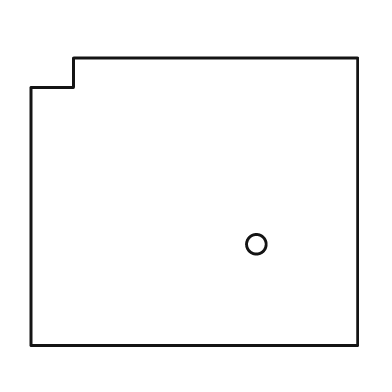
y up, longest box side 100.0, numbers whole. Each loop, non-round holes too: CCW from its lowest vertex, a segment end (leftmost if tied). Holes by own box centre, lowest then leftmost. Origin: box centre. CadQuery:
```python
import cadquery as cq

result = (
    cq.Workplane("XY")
    .moveTo(-50.0, -44.0)
    .lineTo(50.0, -44.0)
    .lineTo(50.0, 44.0)
    .lineTo(-37.0, 44.0)
    .lineTo(-37.0, 35.0)
    .lineTo(-50.0, 35.0)
    .close()
    .moveTo(19.0, -13.0)
    .circle(3.0)
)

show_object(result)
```